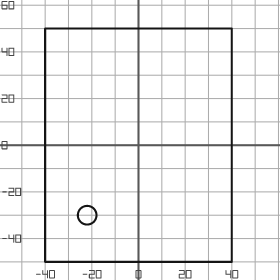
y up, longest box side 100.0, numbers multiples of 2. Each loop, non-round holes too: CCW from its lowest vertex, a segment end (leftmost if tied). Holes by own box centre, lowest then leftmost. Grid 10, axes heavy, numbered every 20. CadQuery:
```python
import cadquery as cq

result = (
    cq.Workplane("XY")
    .moveTo(-40.0, -50.0)
    .lineTo(40.0, -50.0)
    .lineTo(40.0, 50.0)
    .lineTo(-40.0, 50.0)
    .close()
    .moveTo(-22.0, -30.0)
    .circle(4.0)
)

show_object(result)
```